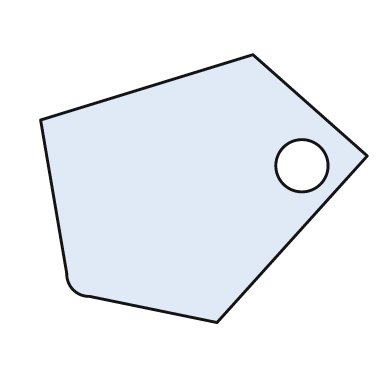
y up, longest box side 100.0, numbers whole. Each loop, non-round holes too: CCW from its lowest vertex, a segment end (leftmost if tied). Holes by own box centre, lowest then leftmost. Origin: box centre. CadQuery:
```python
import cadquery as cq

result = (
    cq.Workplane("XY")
    .moveTo(4.0, -41.0)
    .lineTo(50.0, 10.0)
    .lineTo(15.0, 41.0)
    .lineTo(-50.0, 21.0)
    .lineTo(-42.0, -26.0)
    .threePointArc((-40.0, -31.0), (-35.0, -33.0))
    .close()
    .moveTo(30.0, 7.0)
    .circle(8.0)
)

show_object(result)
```